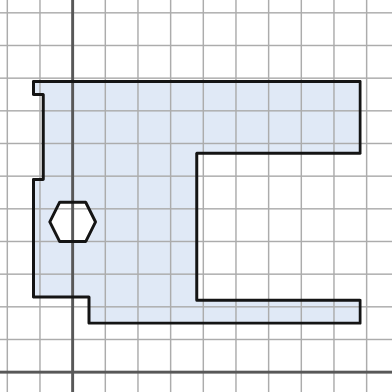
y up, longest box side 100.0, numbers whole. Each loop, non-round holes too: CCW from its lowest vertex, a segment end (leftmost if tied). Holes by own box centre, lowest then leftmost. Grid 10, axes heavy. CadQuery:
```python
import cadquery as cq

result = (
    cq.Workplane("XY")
    .moveTo(5.0, 15.0)
    .lineTo(88.0, 15.0)
    .lineTo(88.0, 22.0)
    .lineTo(38.0, 22.0)
    .lineTo(38.0, 67.0)
    .lineTo(88.0, 67.0)
    .lineTo(88.0, 89.0)
    .lineTo(-12.0, 89.0)
    .lineTo(-12.0, 85.0)
    .lineTo(-9.0, 85.0)
    .lineTo(-9.0, 59.0)
    .lineTo(-12.0, 59.0)
    .lineTo(-12.0, 23.0)
    .lineTo(5.0, 23.0)
    .close()
    .moveTo(-4.0, 40.0)
    .lineTo(4.0, 40.0)
    .lineTo(7.0, 46.0)
    .lineTo(4.0, 52.0)
    .lineTo(-4.0, 52.0)
    .lineTo(-7.0, 46.0)
    .close()
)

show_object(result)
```